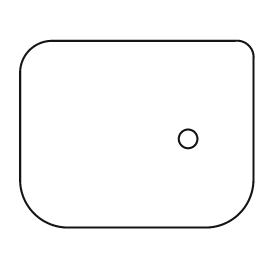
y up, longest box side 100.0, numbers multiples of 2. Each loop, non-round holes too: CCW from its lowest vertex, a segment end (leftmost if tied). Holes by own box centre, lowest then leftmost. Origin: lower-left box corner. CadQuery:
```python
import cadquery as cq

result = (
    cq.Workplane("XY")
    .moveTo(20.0, 0.0)
    .lineTo(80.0, 0.0)
    .threePointArc((94.0, 6.0), (100.0, 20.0))
    .lineTo(100.0, 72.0)
    .threePointArc((98.0, 78.0), (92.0, 80.0))
    .lineTo(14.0, 80.0)
    .threePointArc((4.0, 76.0), (0.0, 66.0))
    .lineTo(0.0, 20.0)
    .threePointArc((6.0, 6.0), (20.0, 0.0))
    .close()
    .moveTo(72.0, 38.0)
    .circle(4.0)
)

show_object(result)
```